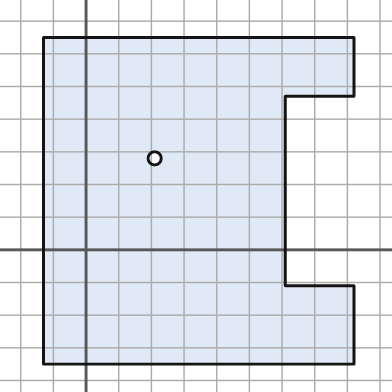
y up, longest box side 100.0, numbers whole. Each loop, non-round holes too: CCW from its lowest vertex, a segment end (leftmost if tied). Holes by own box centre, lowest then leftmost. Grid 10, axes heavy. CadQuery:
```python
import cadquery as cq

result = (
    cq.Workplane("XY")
    .moveTo(-13.0, -35.0)
    .lineTo(82.0, -35.0)
    .lineTo(82.0, -11.0)
    .lineTo(61.0, -11.0)
    .lineTo(61.0, 47.0)
    .lineTo(82.0, 47.0)
    .lineTo(82.0, 65.0)
    .lineTo(-13.0, 65.0)
    .close()
    .moveTo(21.0, 28.0)
    .circle(2.0)
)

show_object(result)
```